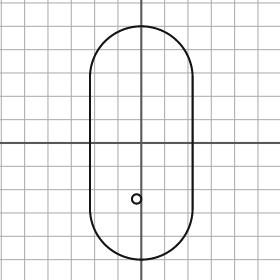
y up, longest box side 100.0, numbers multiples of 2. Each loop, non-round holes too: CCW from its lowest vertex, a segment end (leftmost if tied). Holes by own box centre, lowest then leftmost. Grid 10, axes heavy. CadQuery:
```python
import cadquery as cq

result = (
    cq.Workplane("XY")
    .moveTo(-22.0, -28.0)
    .threePointArc((0.0, -50.0), (22.0, -28.0))
    .lineTo(22.0, 28.0)
    .threePointArc((0.0, 50.0), (-22.0, 28.0))
    .close()
    .moveTo(-2.0, -24.0)
    .circle(2.0)
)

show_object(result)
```